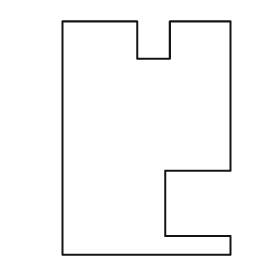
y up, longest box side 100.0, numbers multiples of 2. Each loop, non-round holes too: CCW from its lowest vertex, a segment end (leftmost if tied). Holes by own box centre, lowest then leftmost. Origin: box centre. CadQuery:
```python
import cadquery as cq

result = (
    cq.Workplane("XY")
    .moveTo(-36.0, -50.0)
    .lineTo(36.0, -50.0)
    .lineTo(36.0, -42.0)
    .lineTo(8.0, -42.0)
    .lineTo(8.0, -14.0)
    .lineTo(36.0, -14.0)
    .lineTo(36.0, 50.0)
    .lineTo(10.0, 50.0)
    .lineTo(10.0, 34.0)
    .lineTo(-4.0, 34.0)
    .lineTo(-4.0, 50.0)
    .lineTo(-36.0, 50.0)
    .close()
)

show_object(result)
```